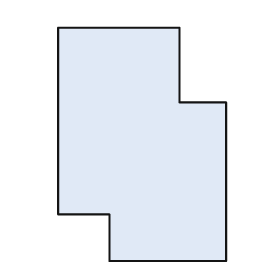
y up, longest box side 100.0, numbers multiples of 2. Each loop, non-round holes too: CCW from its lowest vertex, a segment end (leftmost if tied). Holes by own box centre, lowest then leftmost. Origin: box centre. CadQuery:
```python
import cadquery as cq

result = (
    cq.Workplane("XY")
    .moveTo(-14.0, -50.0)
    .lineTo(36.0, -50.0)
    .lineTo(36.0, 18.0)
    .lineTo(16.0, 18.0)
    .lineTo(16.0, 50.0)
    .lineTo(-36.0, 50.0)
    .lineTo(-36.0, -30.0)
    .lineTo(-14.0, -30.0)
    .close()
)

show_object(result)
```